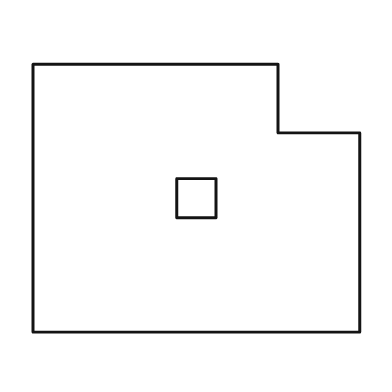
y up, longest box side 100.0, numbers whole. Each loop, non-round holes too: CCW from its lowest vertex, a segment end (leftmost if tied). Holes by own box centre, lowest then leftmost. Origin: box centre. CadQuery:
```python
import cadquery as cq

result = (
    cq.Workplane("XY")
    .moveTo(-50.0, -41.0)
    .lineTo(50.0, -41.0)
    .lineTo(50.0, 20.0)
    .lineTo(25.0, 20.0)
    .lineTo(25.0, 41.0)
    .lineTo(-50.0, 41.0)
    .close()
    .moveTo(-6.0, -6.0)
    .lineTo(6.0, -6.0)
    .lineTo(6.0, 6.0)
    .lineTo(-6.0, 6.0)
    .close()
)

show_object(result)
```